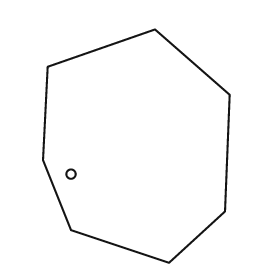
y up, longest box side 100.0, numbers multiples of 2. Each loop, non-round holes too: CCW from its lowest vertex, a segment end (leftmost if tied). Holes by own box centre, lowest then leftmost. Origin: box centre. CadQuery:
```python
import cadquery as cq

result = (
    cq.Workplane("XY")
    .moveTo(14.0, -50.0)
    .lineTo(38.0, -28.0)
    .lineTo(40.0, 22.0)
    .lineTo(8.0, 50.0)
    .lineTo(-38.0, 34.0)
    .lineTo(-40.0, -6.0)
    .lineTo(-28.0, -36.0)
    .close()
    .moveTo(-28.0, -12.0)
    .circle(2.0)
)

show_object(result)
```